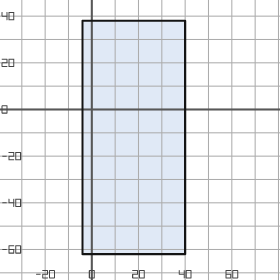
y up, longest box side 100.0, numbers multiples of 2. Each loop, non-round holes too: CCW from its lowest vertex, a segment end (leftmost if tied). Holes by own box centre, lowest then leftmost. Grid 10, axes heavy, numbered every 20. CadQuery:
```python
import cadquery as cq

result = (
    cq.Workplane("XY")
    .moveTo(-4.0, -62.0)
    .lineTo(40.0, -62.0)
    .lineTo(40.0, 38.0)
    .lineTo(-4.0, 38.0)
    .close()
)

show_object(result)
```